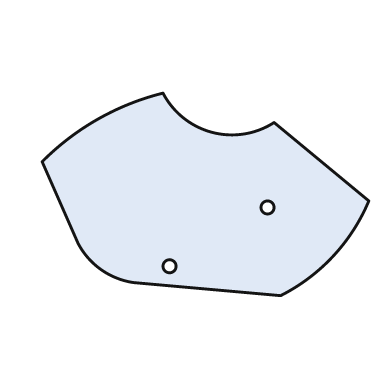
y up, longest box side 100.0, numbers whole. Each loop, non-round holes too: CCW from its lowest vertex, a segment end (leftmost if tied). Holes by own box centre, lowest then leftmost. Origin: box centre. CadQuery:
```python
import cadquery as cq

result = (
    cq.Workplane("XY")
    .moveTo(23.0, -31.0)
    .threePointArc((39.0, -19.0), (50.0, -2.0))
    .lineTo(21.0, 22.0)
    .threePointArc((2.0, 19.0), (-13.0, 31.0))
    .threePointArc((-33.0, 23.0), (-50.0, 10.0))
    .lineTo(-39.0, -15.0)
    .threePointArc((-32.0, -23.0), (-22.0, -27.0))
    .close()
    .moveTo(-11.0, -22.0)
    .circle(2.0)
    .moveTo(19.0, -4.0)
    .circle(2.0)
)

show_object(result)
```